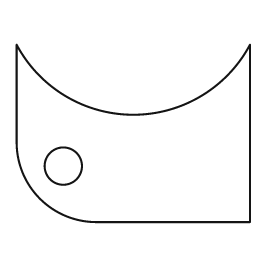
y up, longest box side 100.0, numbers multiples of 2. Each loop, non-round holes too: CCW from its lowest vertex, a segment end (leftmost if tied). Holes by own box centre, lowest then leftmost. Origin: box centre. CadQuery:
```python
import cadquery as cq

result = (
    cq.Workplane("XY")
    .moveTo(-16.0, -38.0)
    .lineTo(50.0, -38.0)
    .lineTo(50.0, 38.0)
    .threePointArc((0.0, 8.0), (-50.0, 38.0))
    .lineTo(-50.0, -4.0)
    .threePointArc((-40.0, -28.0), (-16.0, -38.0))
    .close()
    .moveTo(-30.0, -14.0)
    .circle(8.0)
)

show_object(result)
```